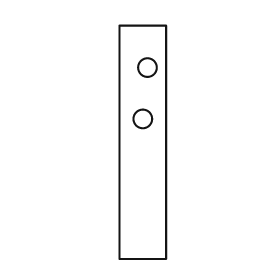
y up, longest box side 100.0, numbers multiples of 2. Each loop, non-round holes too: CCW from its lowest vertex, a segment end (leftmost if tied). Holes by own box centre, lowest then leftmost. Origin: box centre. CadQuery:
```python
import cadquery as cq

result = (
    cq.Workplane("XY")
    .moveTo(-10.0, -50.0)
    .lineTo(10.0, -50.0)
    .lineTo(10.0, 50.0)
    .lineTo(-10.0, 50.0)
    .close()
    .moveTo(0.0, 10.0)
    .circle(4.0)
    .moveTo(2.0, 32.0)
    .circle(4.0)
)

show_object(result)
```